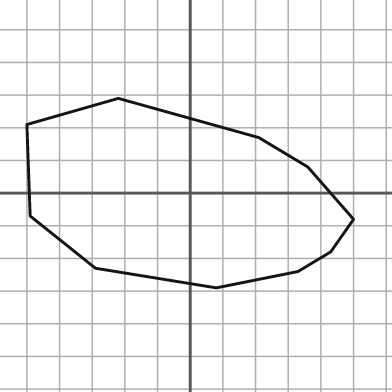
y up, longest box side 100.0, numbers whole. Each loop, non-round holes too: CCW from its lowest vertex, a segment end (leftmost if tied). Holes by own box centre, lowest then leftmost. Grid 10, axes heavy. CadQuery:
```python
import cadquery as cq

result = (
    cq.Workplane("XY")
    .moveTo(8.0, -29.0)
    .lineTo(33.0, -24.0)
    .lineTo(43.0, -18.0)
    .lineTo(50.0, -8.0)
    .lineTo(36.0, 8.0)
    .lineTo(21.0, 17.0)
    .lineTo(-22.0, 29.0)
    .lineTo(-50.0, 21.0)
    .lineTo(-49.0, -7.0)
    .lineTo(-29.0, -23.0)
    .close()
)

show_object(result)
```